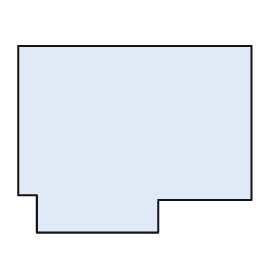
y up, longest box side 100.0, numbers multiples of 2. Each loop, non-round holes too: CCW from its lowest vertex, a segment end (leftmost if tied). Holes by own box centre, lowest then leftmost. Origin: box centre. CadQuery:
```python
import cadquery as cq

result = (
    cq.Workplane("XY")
    .moveTo(-42.0, -40.0)
    .lineTo(10.0, -40.0)
    .lineTo(10.0, -26.0)
    .lineTo(50.0, -26.0)
    .lineTo(50.0, 40.0)
    .lineTo(-50.0, 40.0)
    .lineTo(-50.0, -24.0)
    .lineTo(-42.0, -24.0)
    .close()
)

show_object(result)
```